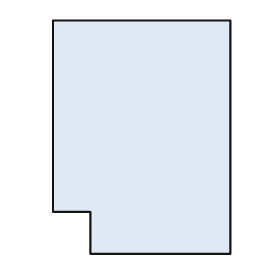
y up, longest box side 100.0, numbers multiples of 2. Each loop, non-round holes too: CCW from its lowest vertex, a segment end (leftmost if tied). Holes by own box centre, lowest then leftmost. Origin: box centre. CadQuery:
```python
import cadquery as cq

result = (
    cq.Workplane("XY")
    .moveTo(-22.0, -50.0)
    .lineTo(38.0, -50.0)
    .lineTo(38.0, 50.0)
    .lineTo(-38.0, 50.0)
    .lineTo(-38.0, -32.0)
    .lineTo(-22.0, -32.0)
    .close()
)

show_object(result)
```